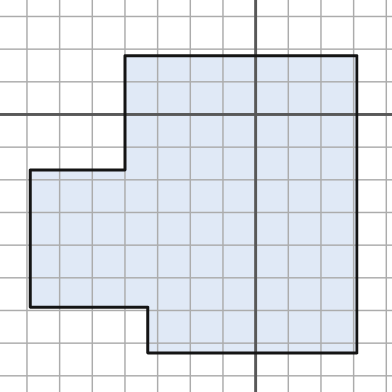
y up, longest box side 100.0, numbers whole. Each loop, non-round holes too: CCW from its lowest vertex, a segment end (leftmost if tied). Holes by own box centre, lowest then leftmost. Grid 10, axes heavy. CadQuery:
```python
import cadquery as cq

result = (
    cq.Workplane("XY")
    .moveTo(-33.0, -73.0)
    .lineTo(31.0, -73.0)
    .lineTo(31.0, 18.0)
    .lineTo(-40.0, 18.0)
    .lineTo(-40.0, -17.0)
    .lineTo(-69.0, -17.0)
    .lineTo(-69.0, -59.0)
    .lineTo(-33.0, -59.0)
    .close()
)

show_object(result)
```